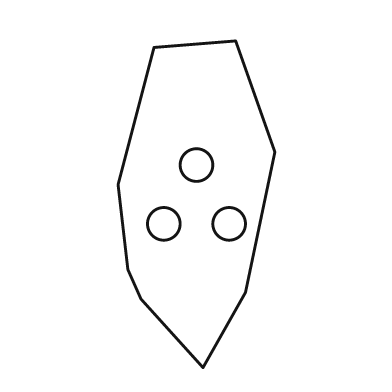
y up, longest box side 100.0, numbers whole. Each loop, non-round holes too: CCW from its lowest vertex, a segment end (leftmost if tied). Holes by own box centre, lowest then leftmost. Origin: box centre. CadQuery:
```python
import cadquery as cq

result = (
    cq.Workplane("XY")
    .moveTo(2.0, -50.0)
    .lineTo(15.0, -27.0)
    .lineTo(24.0, 16.0)
    .lineTo(12.0, 50.0)
    .lineTo(-13.0, 48.0)
    .lineTo(-24.0, 6.0)
    .lineTo(-21.0, -20.0)
    .lineTo(-17.0, -29.0)
    .close()
    .moveTo(-10.0, -6.0)
    .circle(5.0)
    .moveTo(10.0, -6.0)
    .circle(5.0)
    .moveTo(0.0, 12.0)
    .circle(5.0)
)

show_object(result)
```